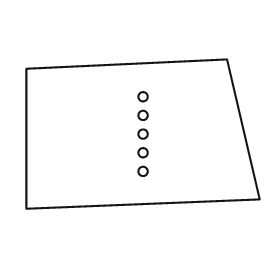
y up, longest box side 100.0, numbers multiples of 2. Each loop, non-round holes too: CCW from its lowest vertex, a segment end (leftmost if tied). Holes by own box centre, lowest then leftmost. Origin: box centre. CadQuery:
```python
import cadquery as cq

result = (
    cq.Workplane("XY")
    .moveTo(-50.0, -32.0)
    .lineTo(50.0, -28.0)
    .lineTo(36.0, 32.0)
    .lineTo(-50.0, 28.0)
    .close()
    .moveTo(0.0, -16.0)
    .circle(2.0)
    .moveTo(0.0, -8.0)
    .circle(2.0)
    .moveTo(0.0, 0.0)
    .circle(2.0)
    .moveTo(0.0, 8.0)
    .circle(2.0)
    .moveTo(0.0, 16.0)
    .circle(2.0)
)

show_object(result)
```